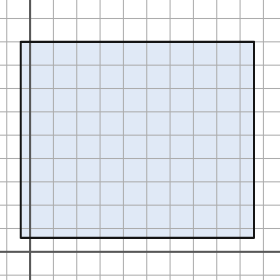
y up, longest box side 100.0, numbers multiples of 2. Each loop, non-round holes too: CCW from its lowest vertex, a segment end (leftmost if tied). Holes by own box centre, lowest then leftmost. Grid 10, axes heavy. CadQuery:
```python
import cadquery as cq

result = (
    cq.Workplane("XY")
    .moveTo(-4.0, 6.0)
    .lineTo(96.0, 6.0)
    .lineTo(96.0, 90.0)
    .lineTo(-4.0, 90.0)
    .close()
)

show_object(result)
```